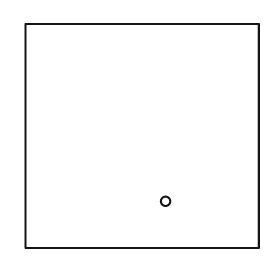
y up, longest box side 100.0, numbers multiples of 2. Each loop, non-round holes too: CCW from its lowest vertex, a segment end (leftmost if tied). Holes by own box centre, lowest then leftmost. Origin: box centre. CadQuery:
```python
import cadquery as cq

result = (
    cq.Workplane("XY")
    .moveTo(-50.0, -48.0)
    .lineTo(50.0, -48.0)
    .lineTo(50.0, 48.0)
    .lineTo(-50.0, 48.0)
    .close()
    .moveTo(10.0, -28.0)
    .circle(2.0)
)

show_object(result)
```